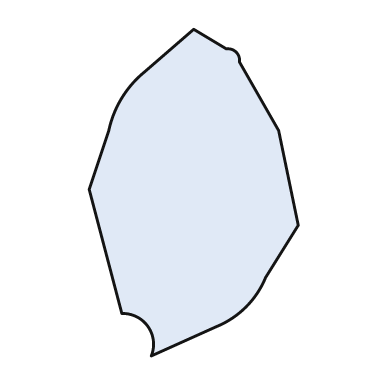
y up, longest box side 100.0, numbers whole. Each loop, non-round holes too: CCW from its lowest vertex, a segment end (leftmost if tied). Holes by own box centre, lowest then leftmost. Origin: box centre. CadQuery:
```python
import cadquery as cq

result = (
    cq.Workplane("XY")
    .moveTo(-13.0, -50.0)
    .lineTo(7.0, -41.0)
    .threePointArc((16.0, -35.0), (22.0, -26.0))
    .lineTo(32.0, -10.0)
    .lineTo(26.0, 19.0)
    .lineTo(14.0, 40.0)
    .threePointArc((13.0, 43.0), (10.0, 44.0))
    .lineTo(0.0, 50.0)
    .lineTo(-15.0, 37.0)
    .threePointArc((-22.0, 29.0), (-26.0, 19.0))
    .lineTo(-32.0, 1.0)
    .lineTo(-22.0, -37.0)
    .threePointArc((-14.0, -41.0), (-13.0, -50.0))
    .close()
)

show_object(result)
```